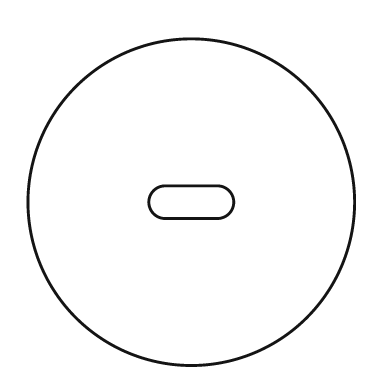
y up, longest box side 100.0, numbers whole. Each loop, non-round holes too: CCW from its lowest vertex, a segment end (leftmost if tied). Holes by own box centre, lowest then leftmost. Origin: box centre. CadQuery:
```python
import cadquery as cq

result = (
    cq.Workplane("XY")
    .moveTo(0.0, 0.0)
    .circle(50.0)
    .moveTo(-8.0, -5.0)
    .lineTo(8.0, -5.0)
    .threePointArc((13.0, 0.0), (8.0, 5.0))
    .lineTo(-8.0, 5.0)
    .threePointArc((-13.0, 0.0), (-8.0, -5.0))
    .close()
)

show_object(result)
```